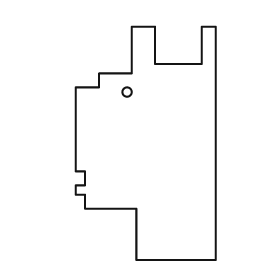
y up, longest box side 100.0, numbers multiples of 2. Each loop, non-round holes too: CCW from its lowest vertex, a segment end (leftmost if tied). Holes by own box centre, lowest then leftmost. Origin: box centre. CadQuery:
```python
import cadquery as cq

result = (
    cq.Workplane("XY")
    .moveTo(-4.0, -50.0)
    .lineTo(30.0, -50.0)
    .lineTo(30.0, 50.0)
    .lineTo(24.0, 50.0)
    .lineTo(24.0, 34.0)
    .lineTo(4.0, 34.0)
    .lineTo(4.0, 50.0)
    .lineTo(-6.0, 50.0)
    .lineTo(-6.0, 30.0)
    .lineTo(-20.0, 30.0)
    .lineTo(-20.0, 24.0)
    .lineTo(-30.0, 24.0)
    .lineTo(-30.0, -12.0)
    .lineTo(-26.0, -12.0)
    .lineTo(-26.0, -18.0)
    .lineTo(-30.0, -18.0)
    .lineTo(-30.0, -22.0)
    .lineTo(-26.0, -22.0)
    .lineTo(-26.0, -28.0)
    .lineTo(-4.0, -28.0)
    .close()
    .moveTo(-8.0, 22.0)
    .circle(2.0)
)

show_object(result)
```